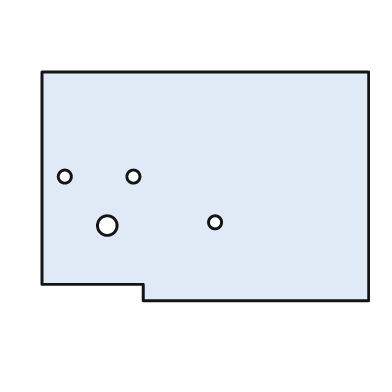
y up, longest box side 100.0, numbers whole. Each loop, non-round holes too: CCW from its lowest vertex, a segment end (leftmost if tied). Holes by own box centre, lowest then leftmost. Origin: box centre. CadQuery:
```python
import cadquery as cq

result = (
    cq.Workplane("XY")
    .moveTo(-19.0, -35.0)
    .lineTo(50.0, -35.0)
    .lineTo(50.0, 35.0)
    .lineTo(-50.0, 35.0)
    .lineTo(-50.0, -30.0)
    .lineTo(-19.0, -30.0)
    .close()
    .moveTo(-30.0, -12.0)
    .circle(3.0)
    .moveTo(3.0, -11.0)
    .circle(2.0)
    .moveTo(-43.0, 3.0)
    .circle(2.0)
    .moveTo(-22.0, 3.0)
    .circle(2.0)
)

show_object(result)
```